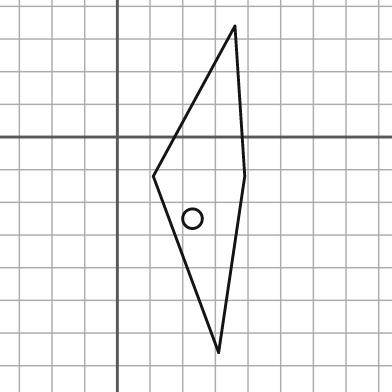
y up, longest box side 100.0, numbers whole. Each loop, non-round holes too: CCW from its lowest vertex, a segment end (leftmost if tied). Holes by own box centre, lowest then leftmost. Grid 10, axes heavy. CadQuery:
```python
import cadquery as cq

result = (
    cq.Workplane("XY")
    .moveTo(31.0, -66.0)
    .lineTo(39.0, -12.0)
    .lineTo(36.0, 34.0)
    .lineTo(11.0, -12.0)
    .close()
    .moveTo(23.0, -25.0)
    .circle(3.0)
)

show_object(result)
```